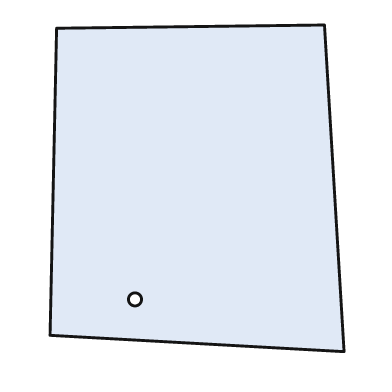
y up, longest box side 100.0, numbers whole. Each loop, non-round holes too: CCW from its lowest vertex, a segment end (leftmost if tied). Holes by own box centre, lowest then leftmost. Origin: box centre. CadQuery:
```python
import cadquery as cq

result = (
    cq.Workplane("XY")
    .moveTo(45.0, -50.0)
    .lineTo(39.0, 50.0)
    .lineTo(-43.0, 49.0)
    .lineTo(-45.0, -45.0)
    .close()
    .moveTo(-19.0, -34.0)
    .circle(2.0)
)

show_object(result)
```